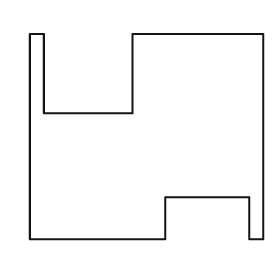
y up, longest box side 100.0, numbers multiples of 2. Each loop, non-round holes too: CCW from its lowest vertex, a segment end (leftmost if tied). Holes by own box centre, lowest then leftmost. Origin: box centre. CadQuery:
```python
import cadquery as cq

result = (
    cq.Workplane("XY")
    .moveTo(-50.0, -44.0)
    .lineTo(8.0, -44.0)
    .lineTo(8.0, -26.0)
    .lineTo(44.0, -26.0)
    .lineTo(44.0, -44.0)
    .lineTo(50.0, -44.0)
    .lineTo(50.0, 44.0)
    .lineTo(-6.0, 44.0)
    .lineTo(-6.0, 10.0)
    .lineTo(-44.0, 10.0)
    .lineTo(-44.0, 44.0)
    .lineTo(-50.0, 44.0)
    .close()
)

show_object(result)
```